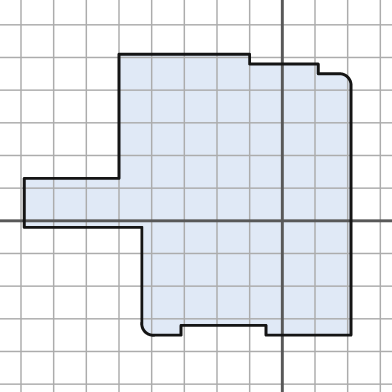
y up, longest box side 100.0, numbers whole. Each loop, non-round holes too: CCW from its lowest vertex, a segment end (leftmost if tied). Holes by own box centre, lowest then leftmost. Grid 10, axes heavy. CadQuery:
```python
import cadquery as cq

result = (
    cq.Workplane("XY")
    .moveTo(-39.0, -35.0)
    .lineTo(-31.0, -35.0)
    .lineTo(-31.0, -32.0)
    .lineTo(-5.0, -32.0)
    .lineTo(-5.0, -35.0)
    .lineTo(21.0, -35.0)
    .lineTo(21.0, 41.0)
    .threePointArc((20.0, 44.0), (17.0, 45.0))
    .lineTo(11.0, 45.0)
    .lineTo(11.0, 48.0)
    .lineTo(-10.0, 48.0)
    .lineTo(-10.0, 51.0)
    .lineTo(-50.0, 51.0)
    .lineTo(-50.0, 13.0)
    .lineTo(-79.0, 13.0)
    .lineTo(-79.0, -2.0)
    .lineTo(-43.0, -2.0)
    .lineTo(-43.0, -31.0)
    .threePointArc((-42.0, -34.0), (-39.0, -35.0))
    .close()
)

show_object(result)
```